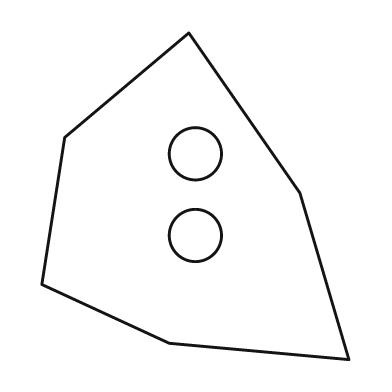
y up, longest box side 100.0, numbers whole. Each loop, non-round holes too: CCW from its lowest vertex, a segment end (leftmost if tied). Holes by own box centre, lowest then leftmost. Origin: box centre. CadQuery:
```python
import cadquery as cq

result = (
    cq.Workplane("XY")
    .moveTo(47.0, -50.0)
    .lineTo(32.0, 1.0)
    .lineTo(-2.0, 50.0)
    .lineTo(-40.0, 18.0)
    .lineTo(-47.0, -27.0)
    .lineTo(-8.0, -45.0)
    .close()
    .moveTo(0.0, -12.0)
    .circle(8.0)
    .moveTo(0.0, 13.0)
    .circle(8.0)
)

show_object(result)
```